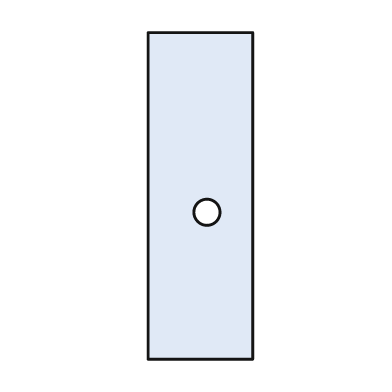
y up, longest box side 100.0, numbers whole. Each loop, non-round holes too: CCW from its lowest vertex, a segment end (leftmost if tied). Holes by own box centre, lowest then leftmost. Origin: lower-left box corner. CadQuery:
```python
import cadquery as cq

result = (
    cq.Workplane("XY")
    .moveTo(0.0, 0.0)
    .lineTo(32.0, 0.0)
    .lineTo(32.0, 100.0)
    .lineTo(0.0, 100.0)
    .close()
    .moveTo(18.0, 45.0)
    .circle(4.0)
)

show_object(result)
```